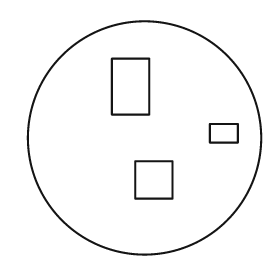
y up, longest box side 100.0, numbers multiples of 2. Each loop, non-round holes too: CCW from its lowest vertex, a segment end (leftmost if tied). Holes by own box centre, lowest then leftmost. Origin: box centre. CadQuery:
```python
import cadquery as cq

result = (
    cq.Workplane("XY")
    .moveTo(0.0, 0.0)
    .circle(50.0)
    .moveTo(-4.0, -26.0)
    .lineTo(12.0, -26.0)
    .lineTo(12.0, -10.0)
    .lineTo(-4.0, -10.0)
    .close()
    .moveTo(28.0, -2.0)
    .lineTo(40.0, -2.0)
    .lineTo(40.0, 6.0)
    .lineTo(28.0, 6.0)
    .close()
    .moveTo(-14.0, 10.0)
    .lineTo(2.0, 10.0)
    .lineTo(2.0, 34.0)
    .lineTo(-14.0, 34.0)
    .close()
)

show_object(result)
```